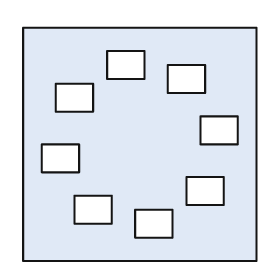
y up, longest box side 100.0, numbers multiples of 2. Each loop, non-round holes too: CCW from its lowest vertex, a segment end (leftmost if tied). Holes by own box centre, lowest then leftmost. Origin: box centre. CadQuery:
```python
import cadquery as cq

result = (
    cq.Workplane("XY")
    .moveTo(-50.0, -50.0)
    .lineTo(50.0, -50.0)
    .lineTo(50.0, 50.0)
    .lineTo(-50.0, 50.0)
    .close()
    .moveTo(-2.0, -40.0)
    .lineTo(14.0, -40.0)
    .lineTo(14.0, -28.0)
    .lineTo(-2.0, -28.0)
    .close()
    .moveTo(-28.0, -34.0)
    .lineTo(-12.0, -34.0)
    .lineTo(-12.0, -22.0)
    .lineTo(-28.0, -22.0)
    .close()
    .moveTo(20.0, -26.0)
    .lineTo(36.0, -26.0)
    .lineTo(36.0, -14.0)
    .lineTo(20.0, -14.0)
    .close()
    .moveTo(-42.0, -12.0)
    .lineTo(-26.0, -12.0)
    .lineTo(-26.0, 0.0)
    .lineTo(-42.0, 0.0)
    .close()
    .moveTo(26.0, 0.0)
    .lineTo(42.0, 0.0)
    .lineTo(42.0, 12.0)
    .lineTo(26.0, 12.0)
    .close()
    .moveTo(-36.0, 14.0)
    .lineTo(-20.0, 14.0)
    .lineTo(-20.0, 26.0)
    .lineTo(-36.0, 26.0)
    .close()
    .moveTo(12.0, 22.0)
    .lineTo(28.0, 22.0)
    .lineTo(28.0, 34.0)
    .lineTo(12.0, 34.0)
    .close()
    .moveTo(-14.0, 28.0)
    .lineTo(2.0, 28.0)
    .lineTo(2.0, 40.0)
    .lineTo(-14.0, 40.0)
    .close()
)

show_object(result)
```